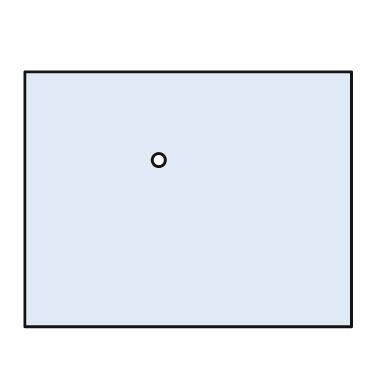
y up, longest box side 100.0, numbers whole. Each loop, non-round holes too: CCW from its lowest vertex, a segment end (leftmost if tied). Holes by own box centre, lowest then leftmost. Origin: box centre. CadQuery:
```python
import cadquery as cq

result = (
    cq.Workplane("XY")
    .moveTo(-50.0, -39.0)
    .lineTo(50.0, -39.0)
    .lineTo(50.0, 39.0)
    .lineTo(-50.0, 39.0)
    .close()
    .moveTo(-9.0, 12.0)
    .circle(2.0)
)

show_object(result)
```